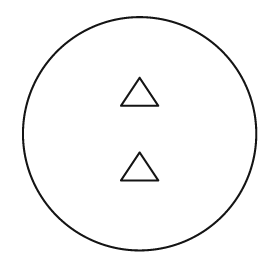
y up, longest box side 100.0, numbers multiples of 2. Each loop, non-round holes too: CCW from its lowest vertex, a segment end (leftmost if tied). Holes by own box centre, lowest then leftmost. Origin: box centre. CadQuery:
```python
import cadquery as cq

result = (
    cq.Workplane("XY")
    .moveTo(0.0, 0.0)
    .circle(50.0)
    .moveTo(-8.0, -20.0)
    .lineTo(8.0, -20.0)
    .lineTo(0.0, -8.0)
    .close()
    .moveTo(-8.0, 12.0)
    .lineTo(8.0, 12.0)
    .lineTo(0.0, 24.0)
    .close()
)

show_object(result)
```